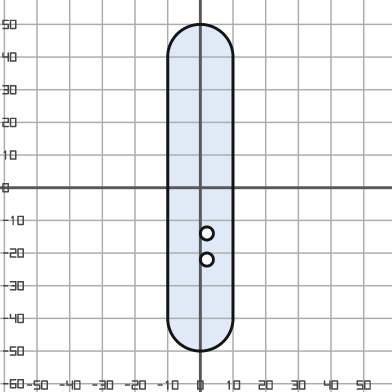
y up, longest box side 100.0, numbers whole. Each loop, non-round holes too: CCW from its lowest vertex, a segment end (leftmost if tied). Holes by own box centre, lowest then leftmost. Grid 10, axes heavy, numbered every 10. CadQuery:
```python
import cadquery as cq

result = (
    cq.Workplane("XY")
    .moveTo(-10.0, -40.0)
    .threePointArc((0.0, -50.0), (10.0, -40.0))
    .lineTo(10.0, 40.0)
    .threePointArc((0.0, 50.0), (-10.0, 40.0))
    .close()
    .moveTo(2.0, -22.0)
    .circle(2.0)
    .moveTo(2.0, -14.0)
    .circle(2.0)
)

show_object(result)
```